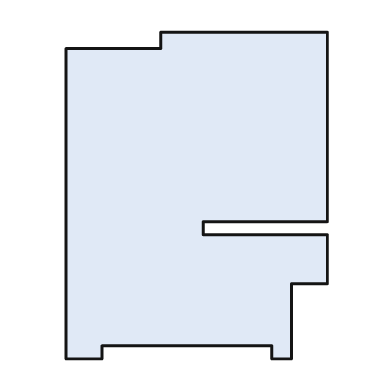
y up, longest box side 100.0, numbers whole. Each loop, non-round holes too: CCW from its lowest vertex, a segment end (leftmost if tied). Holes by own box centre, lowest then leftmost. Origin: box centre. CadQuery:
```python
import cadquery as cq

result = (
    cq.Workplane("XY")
    .moveTo(-40.0, -50.0)
    .lineTo(-29.0, -50.0)
    .lineTo(-29.0, -46.0)
    .lineTo(23.0, -46.0)
    .lineTo(23.0, -50.0)
    .lineTo(29.0, -50.0)
    .lineTo(29.0, -27.0)
    .lineTo(40.0, -27.0)
    .lineTo(40.0, -12.0)
    .lineTo(2.0, -12.0)
    .lineTo(2.0, -8.0)
    .lineTo(40.0, -8.0)
    .lineTo(40.0, 50.0)
    .lineTo(-11.0, 50.0)
    .lineTo(-11.0, 45.0)
    .lineTo(-40.0, 45.0)
    .close()
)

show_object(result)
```